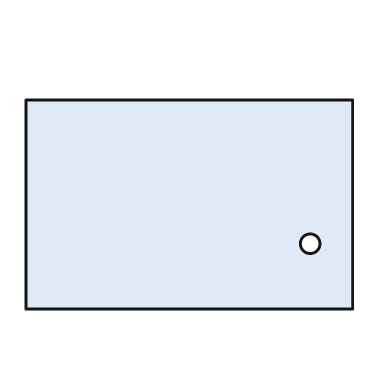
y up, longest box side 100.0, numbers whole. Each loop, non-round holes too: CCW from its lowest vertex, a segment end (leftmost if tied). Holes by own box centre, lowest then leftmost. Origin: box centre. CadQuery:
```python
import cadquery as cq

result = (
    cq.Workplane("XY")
    .moveTo(-50.0, -32.0)
    .lineTo(50.0, -32.0)
    .lineTo(50.0, 32.0)
    .lineTo(-50.0, 32.0)
    .close()
    .moveTo(37.0, -12.0)
    .circle(3.0)
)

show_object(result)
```